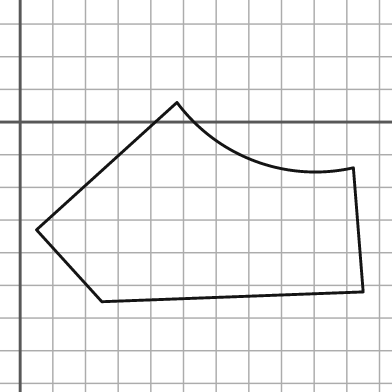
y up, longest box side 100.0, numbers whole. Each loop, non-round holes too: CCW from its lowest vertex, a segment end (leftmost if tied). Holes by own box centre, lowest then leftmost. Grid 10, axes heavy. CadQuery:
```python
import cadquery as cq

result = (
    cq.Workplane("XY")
    .moveTo(25.0, -55.0)
    .lineTo(105.0, -52.0)
    .lineTo(102.0, -14.0)
    .threePointArc((72.0, -12.0), (48.0, 6.0))
    .lineTo(5.0, -33.0)
    .close()
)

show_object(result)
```